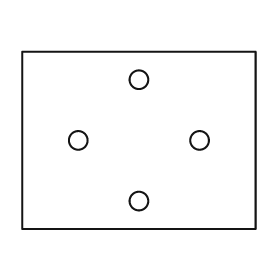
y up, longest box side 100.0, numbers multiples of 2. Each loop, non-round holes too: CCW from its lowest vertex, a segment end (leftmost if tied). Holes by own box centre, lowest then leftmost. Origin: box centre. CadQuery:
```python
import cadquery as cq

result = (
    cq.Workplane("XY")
    .moveTo(-50.0, -38.0)
    .lineTo(50.0, -38.0)
    .lineTo(50.0, 38.0)
    .lineTo(-50.0, 38.0)
    .close()
    .moveTo(0.0, -26.0)
    .circle(4.0)
    .moveTo(-26.0, 0.0)
    .circle(4.0)
    .moveTo(26.0, 0.0)
    .circle(4.0)
    .moveTo(0.0, 26.0)
    .circle(4.0)
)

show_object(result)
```